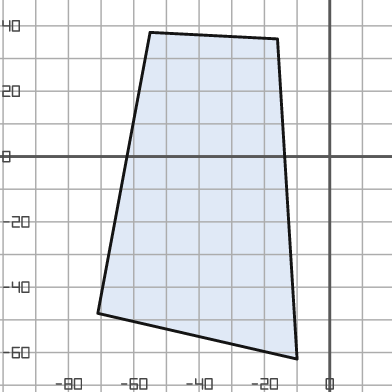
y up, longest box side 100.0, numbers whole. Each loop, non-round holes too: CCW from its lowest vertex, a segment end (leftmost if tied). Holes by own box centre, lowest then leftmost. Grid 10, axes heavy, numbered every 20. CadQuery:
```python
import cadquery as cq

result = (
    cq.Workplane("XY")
    .moveTo(-10.0, -62.0)
    .lineTo(-16.0, 36.0)
    .lineTo(-55.0, 38.0)
    .lineTo(-71.0, -48.0)
    .close()
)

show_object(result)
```